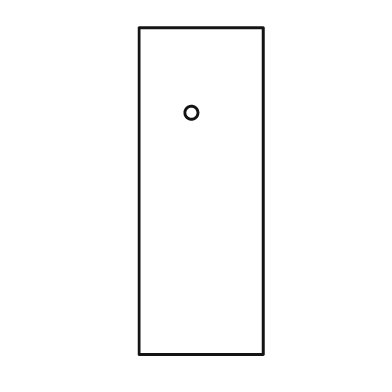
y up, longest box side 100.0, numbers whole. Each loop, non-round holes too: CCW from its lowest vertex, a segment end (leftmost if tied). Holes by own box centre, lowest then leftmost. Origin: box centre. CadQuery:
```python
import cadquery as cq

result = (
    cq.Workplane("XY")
    .moveTo(-19.0, -50.0)
    .lineTo(19.0, -50.0)
    .lineTo(19.0, 50.0)
    .lineTo(-19.0, 50.0)
    .close()
    .moveTo(-3.0, 24.0)
    .circle(2.0)
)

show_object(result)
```